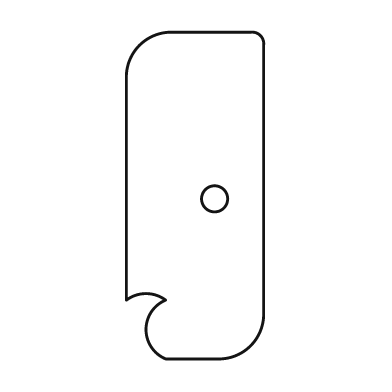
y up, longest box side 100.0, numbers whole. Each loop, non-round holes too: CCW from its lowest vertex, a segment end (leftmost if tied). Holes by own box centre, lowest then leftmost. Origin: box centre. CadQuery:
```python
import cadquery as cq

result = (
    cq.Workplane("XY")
    .moveTo(-9.0, -50.0)
    .lineTo(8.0, -50.0)
    .threePointArc((17.0, -46.0), (21.0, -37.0))
    .lineTo(21.0, 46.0)
    .threePointArc((20.0, 49.0), (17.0, 50.0))
    .lineTo(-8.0, 50.0)
    .threePointArc((-17.0, 46.0), (-21.0, 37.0))
    .lineTo(-21.0, -32.0)
    .threePointArc((-15.0, -30.0), (-9.0, -32.0))
    .threePointArc((-15.0, -41.0), (-9.0, -50.0))
    .close()
    .moveTo(6.0, -1.0)
    .circle(4.0)
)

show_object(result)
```